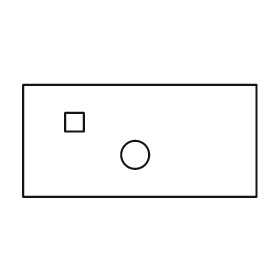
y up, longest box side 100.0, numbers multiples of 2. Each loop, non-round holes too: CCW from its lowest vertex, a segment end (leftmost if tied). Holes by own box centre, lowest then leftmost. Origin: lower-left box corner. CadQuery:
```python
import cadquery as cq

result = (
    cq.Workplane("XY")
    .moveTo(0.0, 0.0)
    .lineTo(100.0, 0.0)
    .lineTo(100.0, 48.0)
    .lineTo(0.0, 48.0)
    .close()
    .moveTo(48.0, 18.0)
    .circle(6.0)
    .moveTo(18.0, 28.0)
    .lineTo(26.0, 28.0)
    .lineTo(26.0, 36.0)
    .lineTo(18.0, 36.0)
    .close()
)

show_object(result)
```